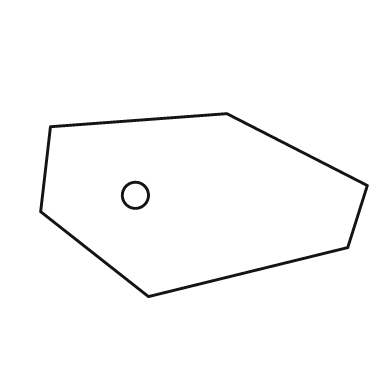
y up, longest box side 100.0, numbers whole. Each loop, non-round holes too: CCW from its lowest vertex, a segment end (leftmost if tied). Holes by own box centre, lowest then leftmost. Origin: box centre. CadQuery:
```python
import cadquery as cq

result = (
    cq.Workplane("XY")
    .moveTo(-17.0, -28.0)
    .lineTo(44.0, -13.0)
    .lineTo(50.0, 6.0)
    .lineTo(7.0, 28.0)
    .lineTo(-47.0, 24.0)
    .lineTo(-50.0, -2.0)
    .close()
    .moveTo(-21.0, 3.0)
    .circle(4.0)
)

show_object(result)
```